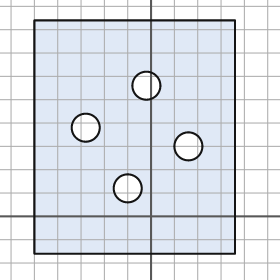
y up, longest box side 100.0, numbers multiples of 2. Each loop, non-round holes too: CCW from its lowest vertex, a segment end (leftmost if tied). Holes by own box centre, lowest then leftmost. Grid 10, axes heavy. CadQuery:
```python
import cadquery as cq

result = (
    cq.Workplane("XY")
    .moveTo(-50.0, -16.0)
    .lineTo(36.0, -16.0)
    .lineTo(36.0, 84.0)
    .lineTo(-50.0, 84.0)
    .close()
    .moveTo(-10.0, 12.0)
    .circle(6.0)
    .moveTo(16.0, 30.0)
    .circle(6.0)
    .moveTo(-28.0, 38.0)
    .circle(6.0)
    .moveTo(-2.0, 56.0)
    .circle(6.0)
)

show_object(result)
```